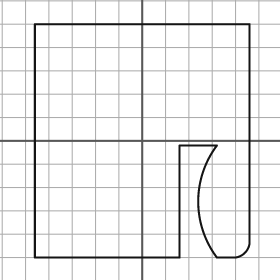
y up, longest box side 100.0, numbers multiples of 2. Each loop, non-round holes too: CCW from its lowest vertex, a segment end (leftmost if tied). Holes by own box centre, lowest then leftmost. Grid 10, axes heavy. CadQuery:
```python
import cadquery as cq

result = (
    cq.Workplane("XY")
    .moveTo(-46.0, -50.0)
    .lineTo(16.0, -50.0)
    .lineTo(16.0, -2.0)
    .lineTo(32.0, -2.0)
    .threePointArc((24.0, -26.0), (32.0, -50.0))
    .lineTo(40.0, -50.0)
    .threePointArc((44.0, -48.0), (46.0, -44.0))
    .lineTo(46.0, 50.0)
    .lineTo(-46.0, 50.0)
    .close()
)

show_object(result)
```